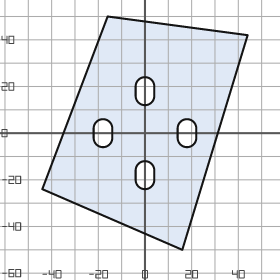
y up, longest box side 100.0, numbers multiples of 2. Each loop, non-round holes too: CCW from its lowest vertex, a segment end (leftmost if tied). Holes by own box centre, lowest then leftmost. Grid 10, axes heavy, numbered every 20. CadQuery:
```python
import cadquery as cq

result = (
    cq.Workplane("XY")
    .moveTo(16.0, -50.0)
    .lineTo(44.0, 42.0)
    .lineTo(-16.0, 50.0)
    .lineTo(-44.0, -24.0)
    .close()
    .moveTo(-4.0, -20.0)
    .threePointArc((0.0, -24.0), (4.0, -20.0))
    .lineTo(4.0, -16.0)
    .threePointArc((0.0, -12.0), (-4.0, -16.0))
    .close()
    .moveTo(-22.0, -2.0)
    .threePointArc((-18.0, -6.0), (-14.0, -2.0))
    .lineTo(-14.0, 2.0)
    .threePointArc((-18.0, 6.0), (-22.0, 2.0))
    .close()
    .moveTo(14.0, -2.0)
    .threePointArc((18.0, -6.0), (22.0, -2.0))
    .lineTo(22.0, 2.0)
    .threePointArc((18.0, 6.0), (14.0, 2.0))
    .close()
    .moveTo(-4.0, 16.0)
    .threePointArc((0.0, 12.0), (4.0, 16.0))
    .lineTo(4.0, 20.0)
    .threePointArc((0.0, 24.0), (-4.0, 20.0))
    .close()
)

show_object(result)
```